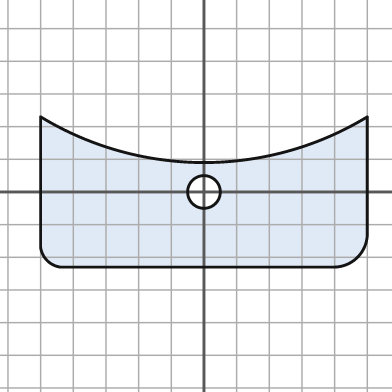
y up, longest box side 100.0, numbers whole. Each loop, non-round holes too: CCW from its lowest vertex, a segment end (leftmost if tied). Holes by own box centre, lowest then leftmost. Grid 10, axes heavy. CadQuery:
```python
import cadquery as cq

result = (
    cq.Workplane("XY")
    .moveTo(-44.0, -23.0)
    .lineTo(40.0, -23.0)
    .threePointArc((47.0, -20.0), (50.0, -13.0))
    .lineTo(50.0, 23.0)
    .threePointArc((0.0, 9.0), (-50.0, 23.0))
    .lineTo(-50.0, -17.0)
    .threePointArc((-48.0, -21.0), (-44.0, -23.0))
    .close()
    .moveTo(0.0, 0.0)
    .circle(5.0)
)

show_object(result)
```